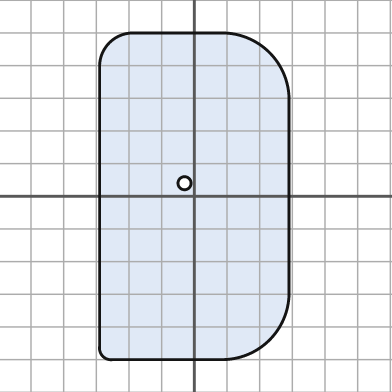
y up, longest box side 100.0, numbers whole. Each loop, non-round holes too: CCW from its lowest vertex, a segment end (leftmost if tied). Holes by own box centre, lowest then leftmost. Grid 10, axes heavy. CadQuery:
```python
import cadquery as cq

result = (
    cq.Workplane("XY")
    .moveTo(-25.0, -50.0)
    .lineTo(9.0, -50.0)
    .threePointArc((23.0, -44.0), (29.0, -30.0))
    .lineTo(29.0, 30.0)
    .threePointArc((23.0, 44.0), (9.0, 50.0))
    .lineTo(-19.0, 50.0)
    .threePointArc((-26.0, 47.0), (-29.0, 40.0))
    .lineTo(-29.0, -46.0)
    .threePointArc((-28.0, -49.0), (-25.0, -50.0))
    .close()
    .moveTo(-3.0, 4.0)
    .circle(2.0)
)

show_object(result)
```